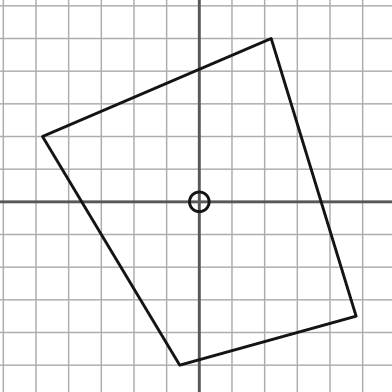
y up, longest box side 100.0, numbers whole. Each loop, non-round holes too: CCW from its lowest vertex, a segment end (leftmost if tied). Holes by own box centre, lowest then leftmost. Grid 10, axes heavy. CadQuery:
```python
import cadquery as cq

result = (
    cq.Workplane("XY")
    .moveTo(-6.0, -50.0)
    .lineTo(48.0, -35.0)
    .lineTo(22.0, 50.0)
    .lineTo(-48.0, 20.0)
    .close()
    .moveTo(0.0, 0.0)
    .circle(3.0)
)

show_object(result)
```